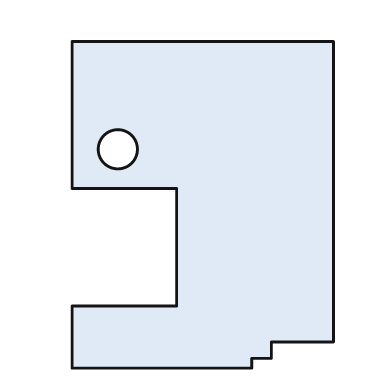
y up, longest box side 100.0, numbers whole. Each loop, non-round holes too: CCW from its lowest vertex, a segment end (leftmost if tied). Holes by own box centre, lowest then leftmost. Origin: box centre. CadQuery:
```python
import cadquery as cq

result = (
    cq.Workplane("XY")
    .moveTo(-40.0, -50.0)
    .lineTo(15.0, -50.0)
    .lineTo(15.0, -47.0)
    .lineTo(21.0, -47.0)
    .lineTo(21.0, -42.0)
    .lineTo(40.0, -42.0)
    .lineTo(40.0, 50.0)
    .lineTo(-40.0, 50.0)
    .lineTo(-40.0, 5.0)
    .lineTo(-8.0, 5.0)
    .lineTo(-8.0, -31.0)
    .lineTo(-40.0, -31.0)
    .close()
    .moveTo(-26.0, 17.0)
    .circle(6.0)
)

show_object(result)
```